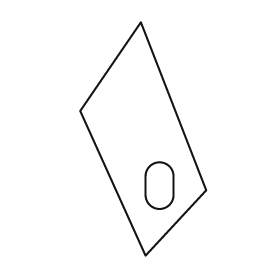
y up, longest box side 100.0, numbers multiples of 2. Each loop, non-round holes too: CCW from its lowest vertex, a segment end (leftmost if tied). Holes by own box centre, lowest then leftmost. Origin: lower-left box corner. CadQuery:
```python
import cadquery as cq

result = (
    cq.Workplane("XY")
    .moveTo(28.0, 0.0)
    .lineTo(54.0, 28.0)
    .lineTo(26.0, 100.0)
    .lineTo(0.0, 62.0)
    .close()
    .moveTo(28.0, 26.0)
    .threePointArc((34.0, 20.0), (40.0, 26.0))
    .lineTo(40.0, 34.0)
    .threePointArc((34.0, 40.0), (28.0, 34.0))
    .close()
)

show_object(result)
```